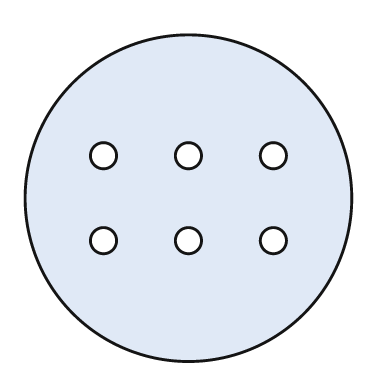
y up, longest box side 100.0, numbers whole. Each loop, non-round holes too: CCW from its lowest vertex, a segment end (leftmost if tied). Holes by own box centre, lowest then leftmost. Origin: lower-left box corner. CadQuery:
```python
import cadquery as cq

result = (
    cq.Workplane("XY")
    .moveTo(50.0, 50.0)
    .circle(50.0)
    .moveTo(24.0, 37.0)
    .circle(4.0)
    .moveTo(50.0, 37.0)
    .circle(4.0)
    .moveTo(76.0, 37.0)
    .circle(4.0)
    .moveTo(24.0, 63.0)
    .circle(4.0)
    .moveTo(50.0, 63.0)
    .circle(4.0)
    .moveTo(76.0, 63.0)
    .circle(4.0)
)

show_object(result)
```